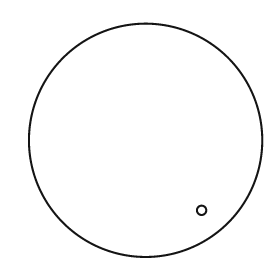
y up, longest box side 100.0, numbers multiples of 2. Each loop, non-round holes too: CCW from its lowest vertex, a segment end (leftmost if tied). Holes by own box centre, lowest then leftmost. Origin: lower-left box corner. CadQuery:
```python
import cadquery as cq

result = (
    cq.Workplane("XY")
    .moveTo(50.0, 50.0)
    .circle(50.0)
    .moveTo(74.0, 20.0)
    .circle(2.0)
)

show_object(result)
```